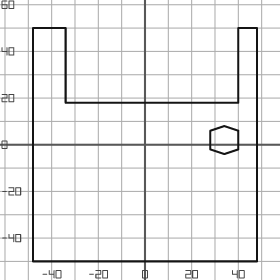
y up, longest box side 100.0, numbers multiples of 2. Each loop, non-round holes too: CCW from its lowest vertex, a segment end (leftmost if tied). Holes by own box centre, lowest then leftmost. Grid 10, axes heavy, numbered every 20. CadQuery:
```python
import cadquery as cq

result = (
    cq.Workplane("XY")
    .moveTo(-48.0, -50.0)
    .lineTo(48.0, -50.0)
    .lineTo(48.0, 50.0)
    .lineTo(40.0, 50.0)
    .lineTo(40.0, 18.0)
    .lineTo(-34.0, 18.0)
    .lineTo(-34.0, 50.0)
    .lineTo(-48.0, 50.0)
    .close()
    .moveTo(34.0, -4.0)
    .lineTo(40.0, -2.0)
    .lineTo(40.0, 6.0)
    .lineTo(34.0, 8.0)
    .lineTo(28.0, 6.0)
    .lineTo(28.0, -2.0)
    .close()
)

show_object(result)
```